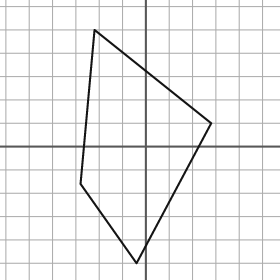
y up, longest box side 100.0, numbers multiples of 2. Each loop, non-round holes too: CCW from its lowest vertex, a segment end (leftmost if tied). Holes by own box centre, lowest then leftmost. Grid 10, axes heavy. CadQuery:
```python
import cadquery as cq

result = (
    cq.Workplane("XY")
    .moveTo(-4.0, -50.0)
    .lineTo(28.0, 10.0)
    .lineTo(-22.0, 50.0)
    .lineTo(-28.0, -16.0)
    .close()
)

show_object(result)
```